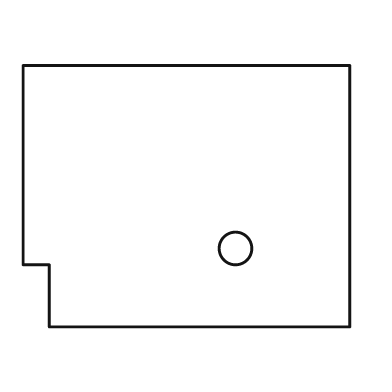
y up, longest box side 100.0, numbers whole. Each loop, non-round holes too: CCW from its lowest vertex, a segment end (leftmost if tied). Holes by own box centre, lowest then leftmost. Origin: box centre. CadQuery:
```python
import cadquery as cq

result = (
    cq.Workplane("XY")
    .moveTo(-42.0, -40.0)
    .lineTo(50.0, -40.0)
    .lineTo(50.0, 40.0)
    .lineTo(-50.0, 40.0)
    .lineTo(-50.0, -21.0)
    .lineTo(-42.0, -21.0)
    .close()
    .moveTo(15.0, -16.0)
    .circle(5.0)
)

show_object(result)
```